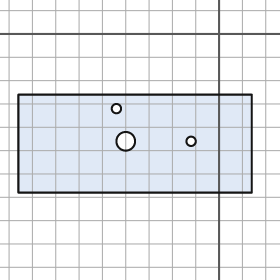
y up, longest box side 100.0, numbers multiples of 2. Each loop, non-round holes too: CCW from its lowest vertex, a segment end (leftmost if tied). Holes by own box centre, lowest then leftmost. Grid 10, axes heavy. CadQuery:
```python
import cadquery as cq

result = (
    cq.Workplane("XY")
    .moveTo(-86.0, -68.0)
    .lineTo(14.0, -68.0)
    .lineTo(14.0, -26.0)
    .lineTo(-86.0, -26.0)
    .close()
    .moveTo(-40.0, -46.0)
    .circle(4.0)
    .moveTo(-12.0, -46.0)
    .circle(2.0)
    .moveTo(-44.0, -32.0)
    .circle(2.0)
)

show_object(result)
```